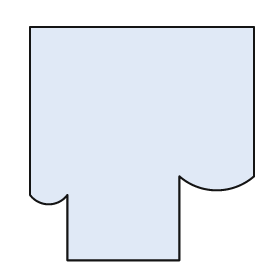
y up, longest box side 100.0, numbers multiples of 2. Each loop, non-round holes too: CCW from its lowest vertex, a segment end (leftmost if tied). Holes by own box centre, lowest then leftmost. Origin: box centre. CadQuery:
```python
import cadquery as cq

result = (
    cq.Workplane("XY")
    .moveTo(-32.0, -50.0)
    .lineTo(16.0, -50.0)
    .lineTo(16.0, -14.0)
    .threePointArc((32.0, -20.0), (48.0, -14.0))
    .lineTo(48.0, 50.0)
    .lineTo(-48.0, 50.0)
    .lineTo(-48.0, -22.0)
    .threePointArc((-40.0, -26.0), (-32.0, -22.0))
    .close()
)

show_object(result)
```